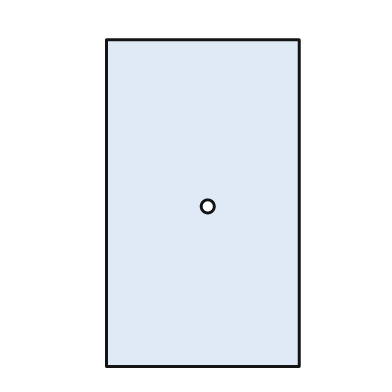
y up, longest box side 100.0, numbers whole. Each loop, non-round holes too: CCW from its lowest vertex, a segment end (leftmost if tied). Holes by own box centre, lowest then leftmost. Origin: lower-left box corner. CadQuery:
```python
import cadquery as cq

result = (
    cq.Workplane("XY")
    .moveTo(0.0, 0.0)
    .lineTo(59.0, 0.0)
    .lineTo(59.0, 100.0)
    .lineTo(0.0, 100.0)
    .close()
    .moveTo(31.0, 49.0)
    .circle(2.0)
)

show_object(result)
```